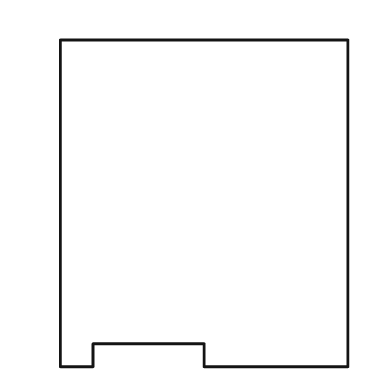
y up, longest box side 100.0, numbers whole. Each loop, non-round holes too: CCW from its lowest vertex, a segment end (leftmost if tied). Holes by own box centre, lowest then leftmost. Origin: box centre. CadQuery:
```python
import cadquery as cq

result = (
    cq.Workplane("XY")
    .moveTo(-44.0, -50.0)
    .lineTo(-34.0, -50.0)
    .lineTo(-34.0, -43.0)
    .lineTo(0.0, -43.0)
    .lineTo(0.0, -50.0)
    .lineTo(44.0, -50.0)
    .lineTo(44.0, 50.0)
    .lineTo(-44.0, 50.0)
    .close()
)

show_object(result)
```